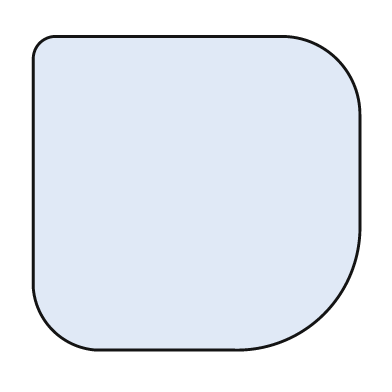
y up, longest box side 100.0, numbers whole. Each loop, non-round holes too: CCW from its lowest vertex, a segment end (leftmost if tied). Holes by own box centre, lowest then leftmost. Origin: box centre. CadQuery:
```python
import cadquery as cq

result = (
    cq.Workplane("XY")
    .moveTo(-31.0, -48.0)
    .lineTo(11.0, -48.0)
    .threePointArc((39.0, -37.0), (50.0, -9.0))
    .lineTo(50.0, 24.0)
    .threePointArc((43.0, 41.0), (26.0, 48.0))
    .lineTo(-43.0, 48.0)
    .threePointArc((-48.0, 46.0), (-50.0, 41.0))
    .lineTo(-50.0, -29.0)
    .threePointArc((-44.0, -42.0), (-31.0, -48.0))
    .close()
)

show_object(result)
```